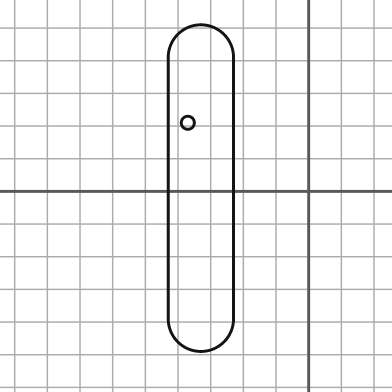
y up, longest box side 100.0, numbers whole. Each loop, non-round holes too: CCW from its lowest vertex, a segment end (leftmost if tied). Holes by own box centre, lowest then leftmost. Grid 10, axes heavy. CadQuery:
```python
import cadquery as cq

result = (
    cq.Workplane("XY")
    .moveTo(-43.0, -39.0)
    .threePointArc((-33.0, -49.0), (-23.0, -39.0))
    .lineTo(-23.0, 41.0)
    .threePointArc((-33.0, 51.0), (-43.0, 41.0))
    .close()
    .moveTo(-37.0, 21.0)
    .circle(2.0)
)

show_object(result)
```